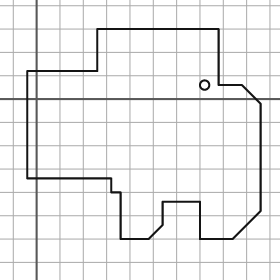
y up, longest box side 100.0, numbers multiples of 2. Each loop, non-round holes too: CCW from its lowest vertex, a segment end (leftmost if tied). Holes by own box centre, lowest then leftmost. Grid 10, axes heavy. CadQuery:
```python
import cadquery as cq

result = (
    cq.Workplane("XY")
    .moveTo(36.0, -60.0)
    .lineTo(48.0, -60.0)
    .lineTo(54.0, -54.0)
    .lineTo(54.0, -44.0)
    .lineTo(70.0, -44.0)
    .lineTo(70.0, -60.0)
    .lineTo(84.0, -60.0)
    .lineTo(96.0, -48.0)
    .lineTo(96.0, -2.0)
    .lineTo(88.0, 6.0)
    .lineTo(78.0, 6.0)
    .lineTo(78.0, 30.0)
    .lineTo(26.0, 30.0)
    .lineTo(26.0, 12.0)
    .lineTo(-4.0, 12.0)
    .lineTo(-4.0, -34.0)
    .lineTo(32.0, -34.0)
    .lineTo(32.0, -40.0)
    .lineTo(36.0, -40.0)
    .close()
    .moveTo(72.0, 6.0)
    .circle(2.0)
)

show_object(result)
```